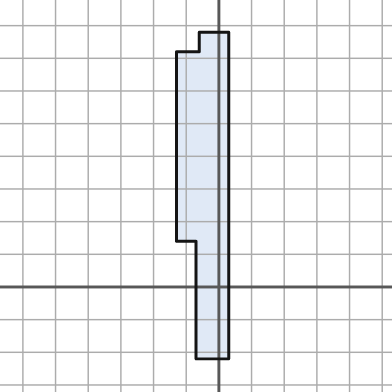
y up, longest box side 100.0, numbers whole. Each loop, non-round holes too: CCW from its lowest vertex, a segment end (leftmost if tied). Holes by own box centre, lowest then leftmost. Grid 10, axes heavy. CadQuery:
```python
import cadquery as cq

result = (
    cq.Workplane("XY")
    .moveTo(-7.0, -22.0)
    .lineTo(3.0, -22.0)
    .lineTo(3.0, 78.0)
    .lineTo(-6.0, 78.0)
    .lineTo(-6.0, 72.0)
    .lineTo(-13.0, 72.0)
    .lineTo(-13.0, 14.0)
    .lineTo(-7.0, 14.0)
    .close()
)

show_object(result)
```